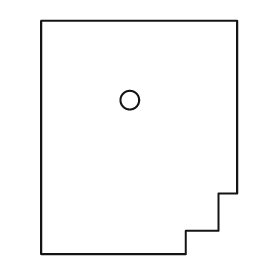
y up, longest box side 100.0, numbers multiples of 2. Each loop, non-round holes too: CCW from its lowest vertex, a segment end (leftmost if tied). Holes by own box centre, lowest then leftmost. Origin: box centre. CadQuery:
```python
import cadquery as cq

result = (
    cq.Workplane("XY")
    .moveTo(-42.0, -50.0)
    .lineTo(20.0, -50.0)
    .lineTo(20.0, -40.0)
    .lineTo(34.0, -40.0)
    .lineTo(34.0, -24.0)
    .lineTo(42.0, -24.0)
    .lineTo(42.0, 50.0)
    .lineTo(-42.0, 50.0)
    .close()
    .moveTo(-4.0, 16.0)
    .circle(4.0)
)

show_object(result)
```